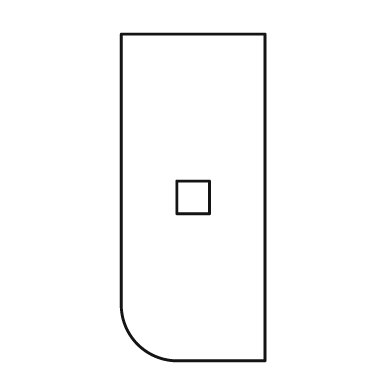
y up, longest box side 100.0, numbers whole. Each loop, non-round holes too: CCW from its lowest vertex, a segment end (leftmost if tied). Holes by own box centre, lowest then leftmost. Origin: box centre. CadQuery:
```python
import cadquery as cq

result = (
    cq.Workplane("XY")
    .moveTo(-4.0, -50.0)
    .lineTo(22.0, -50.0)
    .lineTo(22.0, 50.0)
    .lineTo(-22.0, 50.0)
    .lineTo(-22.0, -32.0)
    .threePointArc((-17.0, -45.0), (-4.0, -50.0))
    .close()
    .moveTo(-5.0, -5.0)
    .lineTo(5.0, -5.0)
    .lineTo(5.0, 5.0)
    .lineTo(-5.0, 5.0)
    .close()
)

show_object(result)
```